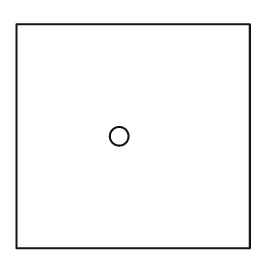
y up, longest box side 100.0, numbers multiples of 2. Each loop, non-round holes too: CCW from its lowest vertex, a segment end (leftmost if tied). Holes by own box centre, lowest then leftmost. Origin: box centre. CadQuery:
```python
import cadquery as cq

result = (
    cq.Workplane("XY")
    .moveTo(-50.0, -48.0)
    .lineTo(50.0, -48.0)
    .lineTo(50.0, 48.0)
    .lineTo(-50.0, 48.0)
    .close()
    .moveTo(-6.0, 0.0)
    .circle(4.0)
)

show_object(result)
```